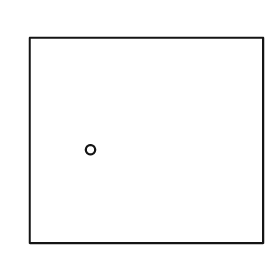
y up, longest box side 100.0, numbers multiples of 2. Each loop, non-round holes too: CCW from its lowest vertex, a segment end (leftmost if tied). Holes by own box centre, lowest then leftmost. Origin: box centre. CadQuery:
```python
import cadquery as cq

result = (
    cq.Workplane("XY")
    .moveTo(-50.0, -44.0)
    .lineTo(50.0, -44.0)
    .lineTo(50.0, 44.0)
    .lineTo(-50.0, 44.0)
    .close()
    .moveTo(-24.0, -4.0)
    .circle(2.0)
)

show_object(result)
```